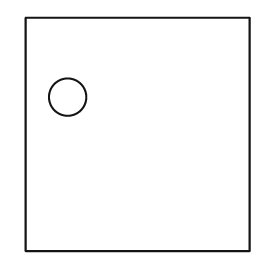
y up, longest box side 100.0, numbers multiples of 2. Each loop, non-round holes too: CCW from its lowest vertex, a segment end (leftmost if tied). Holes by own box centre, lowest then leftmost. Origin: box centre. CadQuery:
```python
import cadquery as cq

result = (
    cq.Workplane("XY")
    .moveTo(-48.0, -50.0)
    .lineTo(48.0, -50.0)
    .lineTo(48.0, 50.0)
    .lineTo(-48.0, 50.0)
    .close()
    .moveTo(-30.0, 16.0)
    .circle(8.0)
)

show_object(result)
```